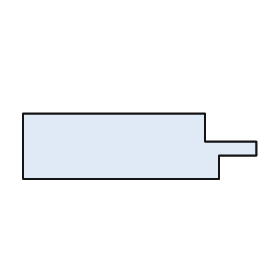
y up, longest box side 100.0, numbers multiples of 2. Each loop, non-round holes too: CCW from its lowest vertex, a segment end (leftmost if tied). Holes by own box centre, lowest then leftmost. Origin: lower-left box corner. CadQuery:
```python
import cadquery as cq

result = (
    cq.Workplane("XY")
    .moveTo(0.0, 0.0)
    .lineTo(84.0, 0.0)
    .lineTo(84.0, 10.0)
    .lineTo(100.0, 10.0)
    .lineTo(100.0, 16.0)
    .lineTo(78.0, 16.0)
    .lineTo(78.0, 28.0)
    .lineTo(0.0, 28.0)
    .close()
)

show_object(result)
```